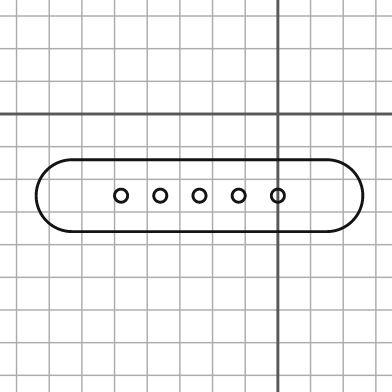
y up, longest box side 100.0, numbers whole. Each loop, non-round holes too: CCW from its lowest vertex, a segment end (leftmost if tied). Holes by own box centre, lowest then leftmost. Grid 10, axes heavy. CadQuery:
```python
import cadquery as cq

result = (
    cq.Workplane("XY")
    .moveTo(-63.0, -36.0)
    .lineTo(15.0, -36.0)
    .threePointArc((26.0, -25.0), (15.0, -14.0))
    .lineTo(-63.0, -14.0)
    .threePointArc((-74.0, -25.0), (-63.0, -36.0))
    .close()
    .moveTo(-48.0, -25.0)
    .circle(2.0)
    .moveTo(-36.0, -25.0)
    .circle(2.0)
    .moveTo(-24.0, -25.0)
    .circle(2.0)
    .moveTo(-12.0, -25.0)
    .circle(2.0)
    .moveTo(0.0, -25.0)
    .circle(2.0)
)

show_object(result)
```